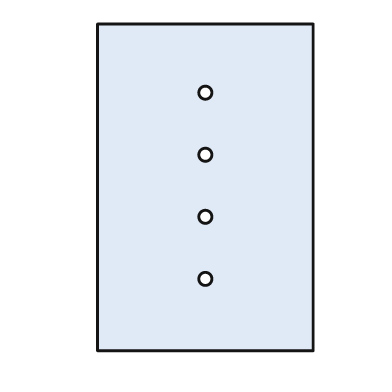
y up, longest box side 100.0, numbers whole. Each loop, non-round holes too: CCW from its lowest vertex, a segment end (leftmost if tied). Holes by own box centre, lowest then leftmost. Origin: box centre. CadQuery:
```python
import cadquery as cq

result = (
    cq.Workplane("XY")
    .moveTo(-33.0, -50.0)
    .lineTo(33.0, -50.0)
    .lineTo(33.0, 50.0)
    .lineTo(-33.0, 50.0)
    .close()
    .moveTo(0.0, -28.0)
    .circle(2.0)
    .moveTo(0.0, -9.0)
    .circle(2.0)
    .moveTo(0.0, 10.0)
    .circle(2.0)
    .moveTo(0.0, 29.0)
    .circle(2.0)
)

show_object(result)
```